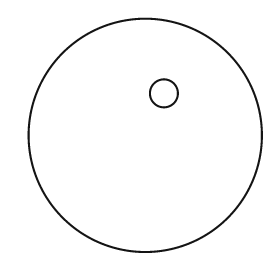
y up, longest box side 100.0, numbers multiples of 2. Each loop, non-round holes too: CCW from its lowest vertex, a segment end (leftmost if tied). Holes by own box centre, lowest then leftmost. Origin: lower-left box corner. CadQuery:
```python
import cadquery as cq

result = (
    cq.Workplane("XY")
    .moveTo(50.0, 50.0)
    .circle(50.0)
    .moveTo(58.0, 68.0)
    .circle(6.0)
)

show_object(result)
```